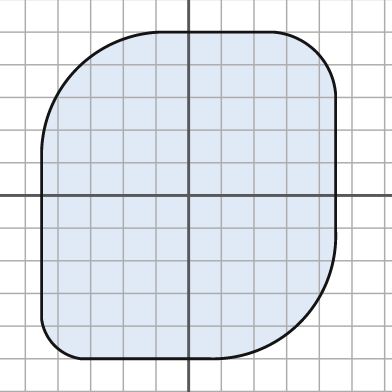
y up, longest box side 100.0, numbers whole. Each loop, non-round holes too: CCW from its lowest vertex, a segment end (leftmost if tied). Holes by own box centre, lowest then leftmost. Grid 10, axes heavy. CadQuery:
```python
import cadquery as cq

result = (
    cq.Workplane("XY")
    .moveTo(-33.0, -50.0)
    .lineTo(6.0, -50.0)
    .threePointArc((34.0, -39.0), (45.0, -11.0))
    .lineTo(45.0, 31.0)
    .threePointArc((39.0, 44.0), (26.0, 50.0))
    .lineTo(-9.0, 50.0)
    .threePointArc((-34.0, 39.0), (-45.0, 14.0))
    .lineTo(-45.0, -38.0)
    .threePointArc((-41.0, -46.0), (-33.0, -50.0))
    .close()
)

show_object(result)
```